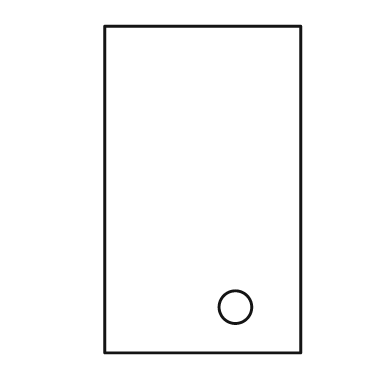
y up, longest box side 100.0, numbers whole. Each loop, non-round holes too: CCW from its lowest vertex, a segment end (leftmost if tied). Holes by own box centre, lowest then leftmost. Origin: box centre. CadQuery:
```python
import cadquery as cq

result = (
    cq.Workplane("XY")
    .moveTo(-30.0, -50.0)
    .lineTo(30.0, -50.0)
    .lineTo(30.0, 50.0)
    .lineTo(-30.0, 50.0)
    .close()
    .moveTo(10.0, -36.0)
    .circle(5.0)
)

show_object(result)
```